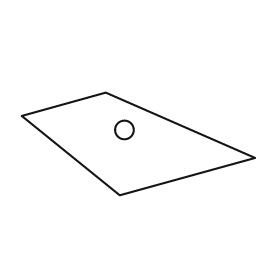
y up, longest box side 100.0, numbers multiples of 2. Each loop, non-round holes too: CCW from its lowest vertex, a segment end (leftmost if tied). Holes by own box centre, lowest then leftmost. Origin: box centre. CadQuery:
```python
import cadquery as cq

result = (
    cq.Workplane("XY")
    .moveTo(-8.0, -22.0)
    .lineTo(50.0, -6.0)
    .lineTo(-14.0, 22.0)
    .lineTo(-50.0, 12.0)
    .close()
    .moveTo(-6.0, 6.0)
    .circle(4.0)
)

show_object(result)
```